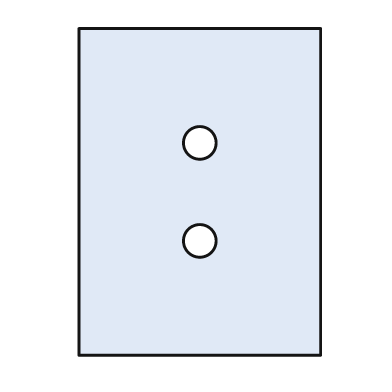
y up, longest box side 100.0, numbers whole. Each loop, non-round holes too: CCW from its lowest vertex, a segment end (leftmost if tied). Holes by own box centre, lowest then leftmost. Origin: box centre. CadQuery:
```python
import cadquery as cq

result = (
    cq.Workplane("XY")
    .moveTo(-37.0, -50.0)
    .lineTo(37.0, -50.0)
    .lineTo(37.0, 50.0)
    .lineTo(-37.0, 50.0)
    .close()
    .moveTo(0.0, -15.0)
    .circle(5.0)
    .moveTo(0.0, 15.0)
    .circle(5.0)
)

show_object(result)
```